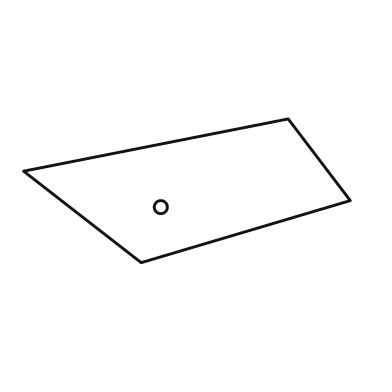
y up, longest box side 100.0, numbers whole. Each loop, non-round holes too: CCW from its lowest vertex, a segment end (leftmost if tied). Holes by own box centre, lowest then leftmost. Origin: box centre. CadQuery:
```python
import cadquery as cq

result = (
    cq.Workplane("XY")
    .moveTo(-14.0, -22.0)
    .lineTo(50.0, -3.0)
    .lineTo(31.0, 22.0)
    .lineTo(-50.0, 6.0)
    .close()
    .moveTo(-8.0, -5.0)
    .circle(2.0)
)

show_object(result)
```